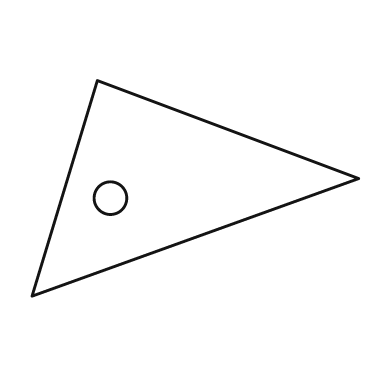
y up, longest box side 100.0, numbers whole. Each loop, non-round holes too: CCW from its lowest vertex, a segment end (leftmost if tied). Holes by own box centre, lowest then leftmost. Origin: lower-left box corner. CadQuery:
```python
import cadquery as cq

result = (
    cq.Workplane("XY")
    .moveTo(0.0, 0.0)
    .lineTo(100.0, 36.0)
    .lineTo(20.0, 66.0)
    .close()
    .moveTo(24.0, 30.0)
    .circle(5.0)
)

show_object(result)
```